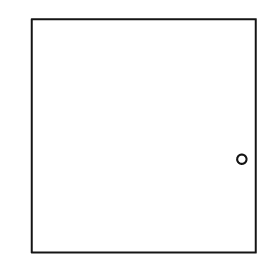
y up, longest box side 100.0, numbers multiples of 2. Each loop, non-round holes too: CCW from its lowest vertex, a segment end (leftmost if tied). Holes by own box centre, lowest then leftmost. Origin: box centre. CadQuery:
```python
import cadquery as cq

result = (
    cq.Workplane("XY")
    .moveTo(-48.0, -50.0)
    .lineTo(48.0, -50.0)
    .lineTo(48.0, 50.0)
    .lineTo(-48.0, 50.0)
    .close()
    .moveTo(42.0, -10.0)
    .circle(2.0)
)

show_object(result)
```